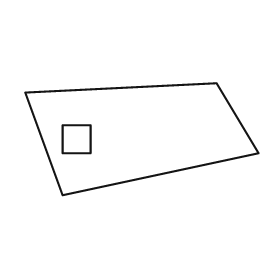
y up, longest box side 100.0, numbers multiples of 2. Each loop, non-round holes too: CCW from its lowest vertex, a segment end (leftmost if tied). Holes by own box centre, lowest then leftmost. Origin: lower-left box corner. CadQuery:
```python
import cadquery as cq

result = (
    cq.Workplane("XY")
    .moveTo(16.0, 0.0)
    .lineTo(100.0, 18.0)
    .lineTo(82.0, 48.0)
    .lineTo(0.0, 44.0)
    .close()
    .moveTo(16.0, 18.0)
    .lineTo(28.0, 18.0)
    .lineTo(28.0, 30.0)
    .lineTo(16.0, 30.0)
    .close()
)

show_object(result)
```